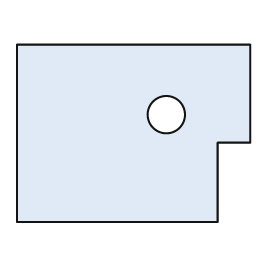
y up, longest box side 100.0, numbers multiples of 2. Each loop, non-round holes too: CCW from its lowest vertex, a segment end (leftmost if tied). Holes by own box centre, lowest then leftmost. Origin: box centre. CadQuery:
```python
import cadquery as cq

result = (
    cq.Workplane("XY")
    .moveTo(-50.0, -38.0)
    .lineTo(36.0, -38.0)
    .lineTo(36.0, -4.0)
    .lineTo(50.0, -4.0)
    .lineTo(50.0, 38.0)
    .lineTo(-50.0, 38.0)
    .close()
    .moveTo(14.0, 8.0)
    .circle(8.0)
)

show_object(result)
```